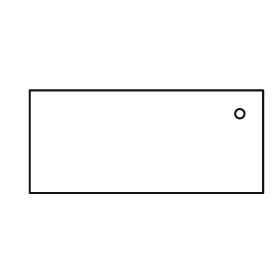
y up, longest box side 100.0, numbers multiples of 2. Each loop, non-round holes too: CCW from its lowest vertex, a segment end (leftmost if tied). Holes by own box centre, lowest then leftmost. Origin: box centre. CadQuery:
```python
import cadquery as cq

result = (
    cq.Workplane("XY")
    .moveTo(-50.0, -22.0)
    .lineTo(50.0, -22.0)
    .lineTo(50.0, 22.0)
    .lineTo(-50.0, 22.0)
    .close()
    .moveTo(40.0, 12.0)
    .circle(2.0)
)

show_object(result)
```